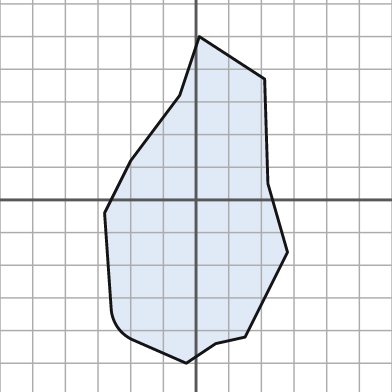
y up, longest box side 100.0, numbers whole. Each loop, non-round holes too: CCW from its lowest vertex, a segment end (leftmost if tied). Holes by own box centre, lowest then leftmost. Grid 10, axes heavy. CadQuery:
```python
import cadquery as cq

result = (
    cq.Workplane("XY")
    .moveTo(-3.0, -50.0)
    .lineTo(6.0, -44.0)
    .lineTo(15.0, -42.0)
    .lineTo(28.0, -16.0)
    .lineTo(22.0, 5.0)
    .lineTo(21.0, 37.0)
    .lineTo(1.0, 50.0)
    .lineTo(-5.0, 32.0)
    .lineTo(-20.0, 12.0)
    .lineTo(-28.0, -4.0)
    .lineTo(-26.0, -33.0)
    .threePointArc((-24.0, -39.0), (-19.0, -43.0))
    .close()
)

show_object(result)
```